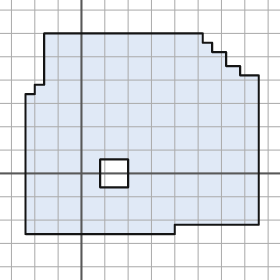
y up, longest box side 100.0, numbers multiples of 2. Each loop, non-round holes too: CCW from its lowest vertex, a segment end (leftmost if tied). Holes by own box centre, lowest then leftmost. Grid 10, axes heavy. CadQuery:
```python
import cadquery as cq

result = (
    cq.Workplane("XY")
    .moveTo(-24.0, -26.0)
    .lineTo(40.0, -26.0)
    .lineTo(40.0, -22.0)
    .lineTo(76.0, -22.0)
    .lineTo(76.0, 42.0)
    .lineTo(68.0, 42.0)
    .lineTo(68.0, 46.0)
    .lineTo(62.0, 46.0)
    .lineTo(62.0, 52.0)
    .lineTo(56.0, 52.0)
    .lineTo(56.0, 56.0)
    .lineTo(52.0, 56.0)
    .lineTo(52.0, 60.0)
    .lineTo(-16.0, 60.0)
    .lineTo(-16.0, 38.0)
    .lineTo(-20.0, 38.0)
    .lineTo(-20.0, 34.0)
    .lineTo(-24.0, 34.0)
    .close()
    .moveTo(8.0, -6.0)
    .lineTo(20.0, -6.0)
    .lineTo(20.0, 6.0)
    .lineTo(8.0, 6.0)
    .close()
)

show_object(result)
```